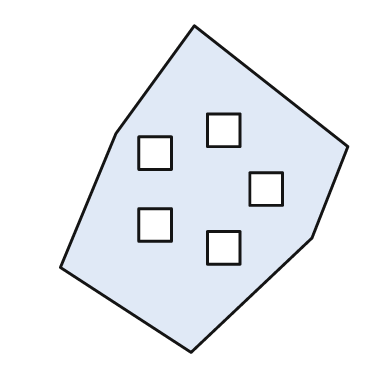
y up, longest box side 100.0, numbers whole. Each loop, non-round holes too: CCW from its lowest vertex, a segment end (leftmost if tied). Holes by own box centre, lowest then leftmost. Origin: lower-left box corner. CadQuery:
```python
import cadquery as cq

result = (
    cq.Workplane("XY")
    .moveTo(40.0, 0.0)
    .lineTo(77.0, 35.0)
    .lineTo(88.0, 63.0)
    .lineTo(41.0, 100.0)
    .lineTo(17.0, 67.0)
    .lineTo(0.0, 26.0)
    .close()
    .moveTo(45.0, 27.0)
    .lineTo(55.0, 27.0)
    .lineTo(55.0, 37.0)
    .lineTo(45.0, 37.0)
    .close()
    .moveTo(24.0, 34.0)
    .lineTo(34.0, 34.0)
    .lineTo(34.0, 44.0)
    .lineTo(24.0, 44.0)
    .close()
    .moveTo(58.0, 45.0)
    .lineTo(68.0, 45.0)
    .lineTo(68.0, 55.0)
    .lineTo(58.0, 55.0)
    .close()
    .moveTo(24.0, 56.0)
    .lineTo(34.0, 56.0)
    .lineTo(34.0, 66.0)
    .lineTo(24.0, 66.0)
    .close()
    .moveTo(45.0, 63.0)
    .lineTo(55.0, 63.0)
    .lineTo(55.0, 73.0)
    .lineTo(45.0, 73.0)
    .close()
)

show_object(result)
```